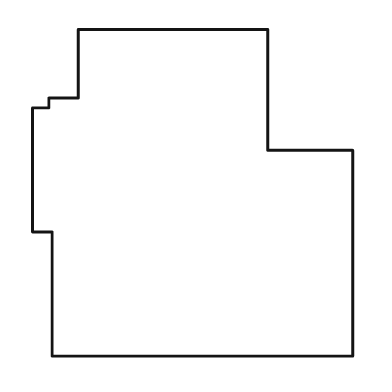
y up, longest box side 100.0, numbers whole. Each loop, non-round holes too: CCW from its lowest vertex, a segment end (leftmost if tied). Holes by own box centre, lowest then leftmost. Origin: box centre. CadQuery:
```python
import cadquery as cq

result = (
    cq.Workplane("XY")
    .moveTo(-43.0, -50.0)
    .lineTo(49.0, -50.0)
    .lineTo(49.0, 13.0)
    .lineTo(23.0, 13.0)
    .lineTo(23.0, 50.0)
    .lineTo(-35.0, 50.0)
    .lineTo(-35.0, 29.0)
    .lineTo(-44.0, 29.0)
    .lineTo(-44.0, 26.0)
    .lineTo(-49.0, 26.0)
    .lineTo(-49.0, -12.0)
    .lineTo(-43.0, -12.0)
    .close()
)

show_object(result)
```